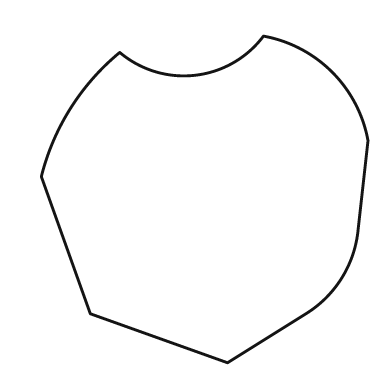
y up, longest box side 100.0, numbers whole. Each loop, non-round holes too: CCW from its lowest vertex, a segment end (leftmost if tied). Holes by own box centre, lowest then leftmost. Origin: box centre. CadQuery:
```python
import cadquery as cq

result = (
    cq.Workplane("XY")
    .moveTo(7.0, -50.0)
    .lineTo(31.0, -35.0)
    .threePointArc((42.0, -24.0), (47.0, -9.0))
    .lineTo(50.0, 18.0)
    .threePointArc((39.0, 39.0), (18.0, 50.0))
    .threePointArc((-3.0, 38.0), (-26.0, 45.0))
    .threePointArc((-41.0, 28.0), (-50.0, 7.0))
    .lineTo(-35.0, -35.0)
    .close()
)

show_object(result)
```